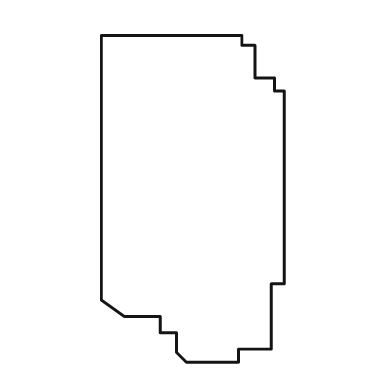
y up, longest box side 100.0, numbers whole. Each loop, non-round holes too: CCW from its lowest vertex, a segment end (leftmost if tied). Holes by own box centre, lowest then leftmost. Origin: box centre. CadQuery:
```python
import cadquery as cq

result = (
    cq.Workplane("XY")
    .moveTo(-2.0, -50.0)
    .lineTo(14.0, -50.0)
    .lineTo(14.0, -46.0)
    .lineTo(24.0, -46.0)
    .lineTo(24.0, -26.0)
    .lineTo(28.0, -26.0)
    .lineTo(28.0, 33.0)
    .lineTo(25.0, 33.0)
    .lineTo(25.0, 37.0)
    .lineTo(19.0, 37.0)
    .lineTo(19.0, 47.0)
    .lineTo(15.0, 47.0)
    .lineTo(15.0, 50.0)
    .lineTo(-28.0, 50.0)
    .lineTo(-28.0, -31.0)
    .lineTo(-21.0, -36.0)
    .lineTo(-10.0, -36.0)
    .lineTo(-10.0, -41.0)
    .lineTo(-5.0, -41.0)
    .lineTo(-5.0, -47.0)
    .close()
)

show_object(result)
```